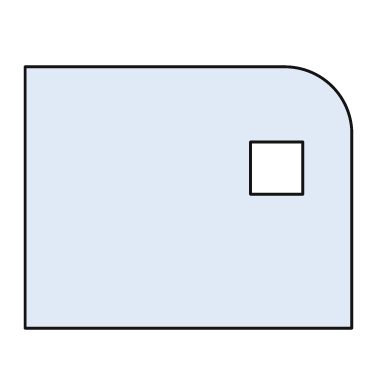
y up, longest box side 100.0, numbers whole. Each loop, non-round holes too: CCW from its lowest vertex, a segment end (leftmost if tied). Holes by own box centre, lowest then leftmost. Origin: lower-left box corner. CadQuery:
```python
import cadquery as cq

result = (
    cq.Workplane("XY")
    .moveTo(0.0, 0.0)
    .lineTo(100.0, 0.0)
    .lineTo(100.0, 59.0)
    .threePointArc((94.0, 74.0), (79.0, 80.0))
    .lineTo(0.0, 80.0)
    .close()
    .moveTo(69.0, 41.0)
    .lineTo(85.0, 41.0)
    .lineTo(85.0, 57.0)
    .lineTo(69.0, 57.0)
    .close()
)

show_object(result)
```